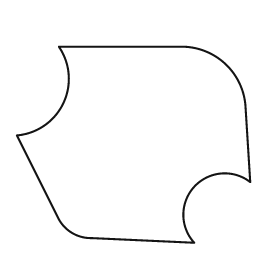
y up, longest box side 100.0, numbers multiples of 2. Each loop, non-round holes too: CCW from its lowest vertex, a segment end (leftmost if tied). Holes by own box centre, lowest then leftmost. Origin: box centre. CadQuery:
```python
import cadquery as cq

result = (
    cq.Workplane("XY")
    .moveTo(26.0, -42.0)
    .threePointArc((26.0, -18.0), (50.0, -16.0))
    .lineTo(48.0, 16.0)
    .threePointArc((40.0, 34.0), (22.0, 42.0))
    .lineTo(-32.0, 42.0)
    .threePointArc((-30.0, 18.0), (-50.0, 4.0))
    .lineTo(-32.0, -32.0)
    .threePointArc((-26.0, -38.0), (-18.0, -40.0))
    .close()
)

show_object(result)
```